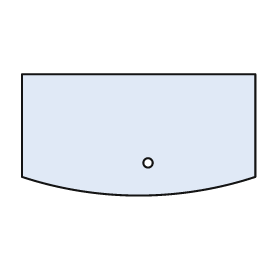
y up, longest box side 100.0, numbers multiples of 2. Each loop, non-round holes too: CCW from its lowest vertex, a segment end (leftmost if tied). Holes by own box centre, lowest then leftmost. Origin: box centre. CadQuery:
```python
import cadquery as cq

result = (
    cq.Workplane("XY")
    .moveTo(-50.0, -18.0)
    .threePointArc((0.0, -26.0), (50.0, -18.0))
    .lineTo(50.0, 26.0)
    .lineTo(-50.0, 26.0)
    .close()
    .moveTo(4.0, -12.0)
    .circle(2.0)
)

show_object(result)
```